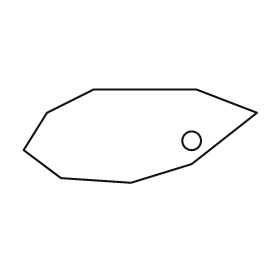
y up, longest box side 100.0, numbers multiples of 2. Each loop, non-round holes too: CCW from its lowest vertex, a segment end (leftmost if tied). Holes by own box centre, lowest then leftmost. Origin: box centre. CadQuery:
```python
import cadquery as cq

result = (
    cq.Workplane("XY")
    .moveTo(-4.0, -20.0)
    .lineTo(22.0, -12.0)
    .lineTo(50.0, 10.0)
    .lineTo(24.0, 20.0)
    .lineTo(-20.0, 20.0)
    .lineTo(-40.0, 10.0)
    .lineTo(-50.0, -6.0)
    .lineTo(-34.0, -18.0)
    .close()
    .moveTo(22.0, -2.0)
    .circle(4.0)
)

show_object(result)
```